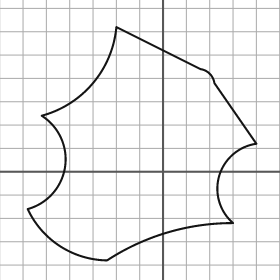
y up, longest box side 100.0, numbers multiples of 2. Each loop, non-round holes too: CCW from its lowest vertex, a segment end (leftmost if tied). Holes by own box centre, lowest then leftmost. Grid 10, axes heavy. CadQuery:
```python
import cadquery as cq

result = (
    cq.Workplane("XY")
    .moveTo(-24.0, -38.0)
    .threePointArc((2.0, -26.0), (30.0, -22.0))
    .threePointArc((24.0, -2.0), (40.0, 12.0))
    .lineTo(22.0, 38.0)
    .threePointArc((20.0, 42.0), (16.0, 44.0))
    .lineTo(-20.0, 62.0)
    .threePointArc((-30.0, 38.0), (-52.0, 24.0))
    .threePointArc((-42.0, 2.0), (-58.0, -16.0))
    .threePointArc((-44.0, -32.0), (-24.0, -38.0))
    .close()
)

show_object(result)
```